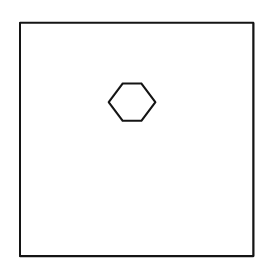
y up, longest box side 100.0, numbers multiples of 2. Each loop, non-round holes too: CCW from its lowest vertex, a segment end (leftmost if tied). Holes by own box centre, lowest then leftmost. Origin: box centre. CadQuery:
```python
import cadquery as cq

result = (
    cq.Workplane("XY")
    .moveTo(-50.0, -50.0)
    .lineTo(50.0, -50.0)
    .lineTo(50.0, 50.0)
    .lineTo(-50.0, 50.0)
    .close()
    .moveTo(-6.0, 8.0)
    .lineTo(2.0, 8.0)
    .lineTo(8.0, 16.0)
    .lineTo(2.0, 24.0)
    .lineTo(-6.0, 24.0)
    .lineTo(-12.0, 16.0)
    .close()
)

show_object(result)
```